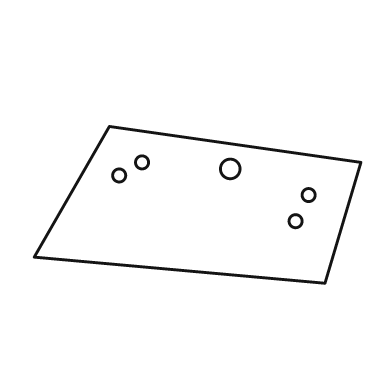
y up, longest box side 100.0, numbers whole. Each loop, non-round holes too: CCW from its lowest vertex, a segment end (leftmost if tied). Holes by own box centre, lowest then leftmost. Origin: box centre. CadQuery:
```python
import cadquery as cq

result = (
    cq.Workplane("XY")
    .moveTo(39.0, -24.0)
    .lineTo(50.0, 13.0)
    .lineTo(-27.0, 24.0)
    .lineTo(-50.0, -16.0)
    .close()
    .moveTo(30.0, -5.0)
    .circle(2.0)
    .moveTo(34.0, 3.0)
    .circle(2.0)
    .moveTo(-24.0, 9.0)
    .circle(2.0)
    .moveTo(10.0, 11.0)
    .circle(3.0)
    .moveTo(-17.0, 13.0)
    .circle(2.0)
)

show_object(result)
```